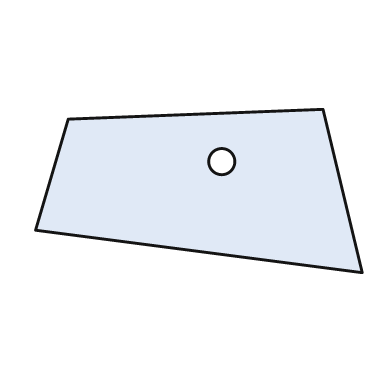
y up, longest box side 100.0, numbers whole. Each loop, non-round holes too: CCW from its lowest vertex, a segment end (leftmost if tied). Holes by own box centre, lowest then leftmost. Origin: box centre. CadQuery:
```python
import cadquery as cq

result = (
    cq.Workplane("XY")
    .moveTo(50.0, -25.0)
    .lineTo(38.0, 25.0)
    .lineTo(-40.0, 22.0)
    .lineTo(-50.0, -12.0)
    .close()
    .moveTo(7.0, 9.0)
    .circle(4.0)
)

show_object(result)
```